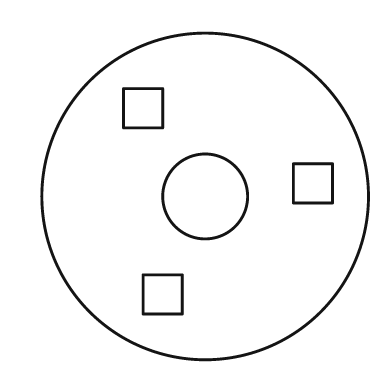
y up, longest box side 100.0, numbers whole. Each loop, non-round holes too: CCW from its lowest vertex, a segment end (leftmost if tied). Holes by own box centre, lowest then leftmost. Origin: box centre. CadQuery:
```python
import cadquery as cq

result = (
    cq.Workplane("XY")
    .moveTo(0.0, 0.0)
    .circle(50.0)
    .moveTo(-19.0, -36.0)
    .lineTo(-7.0, -36.0)
    .lineTo(-7.0, -24.0)
    .lineTo(-19.0, -24.0)
    .close()
    .moveTo(0.0, 0.0)
    .circle(13.0)
    .moveTo(27.0, -2.0)
    .lineTo(39.0, -2.0)
    .lineTo(39.0, 10.0)
    .lineTo(27.0, 10.0)
    .close()
    .moveTo(-25.0, 21.0)
    .lineTo(-13.0, 21.0)
    .lineTo(-13.0, 33.0)
    .lineTo(-25.0, 33.0)
    .close()
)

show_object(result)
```